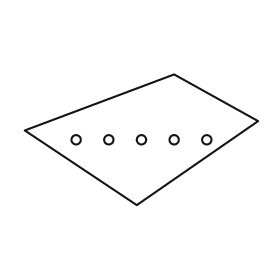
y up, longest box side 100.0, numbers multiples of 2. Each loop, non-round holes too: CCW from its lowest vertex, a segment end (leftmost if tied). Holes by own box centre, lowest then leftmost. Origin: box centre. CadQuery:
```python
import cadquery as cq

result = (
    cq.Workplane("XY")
    .moveTo(-2.0, -28.0)
    .lineTo(50.0, 8.0)
    .lineTo(14.0, 28.0)
    .lineTo(-50.0, 4.0)
    .close()
    .moveTo(-28.0, 0.0)
    .circle(2.0)
    .moveTo(-14.0, 0.0)
    .circle(2.0)
    .moveTo(0.0, 0.0)
    .circle(2.0)
    .moveTo(14.0, 0.0)
    .circle(2.0)
    .moveTo(28.0, 0.0)
    .circle(2.0)
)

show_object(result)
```